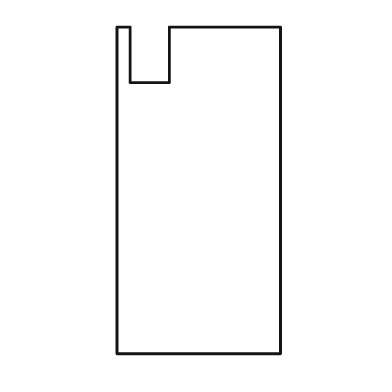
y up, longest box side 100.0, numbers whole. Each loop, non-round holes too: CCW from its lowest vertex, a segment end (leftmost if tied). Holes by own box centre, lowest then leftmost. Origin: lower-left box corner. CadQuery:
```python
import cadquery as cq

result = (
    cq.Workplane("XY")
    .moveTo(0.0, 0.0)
    .lineTo(50.0, 0.0)
    .lineTo(50.0, 100.0)
    .lineTo(16.0, 100.0)
    .lineTo(16.0, 83.0)
    .lineTo(4.0, 83.0)
    .lineTo(4.0, 100.0)
    .lineTo(0.0, 100.0)
    .close()
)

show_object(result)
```